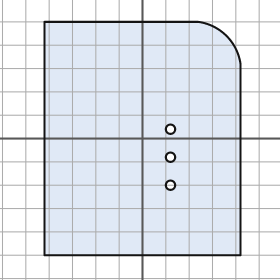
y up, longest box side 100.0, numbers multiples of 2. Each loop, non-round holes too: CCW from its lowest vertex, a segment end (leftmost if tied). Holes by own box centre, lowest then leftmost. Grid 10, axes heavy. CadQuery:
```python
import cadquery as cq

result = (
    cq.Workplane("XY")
    .moveTo(-42.0, -50.0)
    .lineTo(42.0, -50.0)
    .lineTo(42.0, 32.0)
    .threePointArc((36.0, 44.0), (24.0, 50.0))
    .lineTo(-42.0, 50.0)
    .close()
    .moveTo(12.0, -20.0)
    .circle(2.0)
    .moveTo(12.0, -8.0)
    .circle(2.0)
    .moveTo(12.0, 4.0)
    .circle(2.0)
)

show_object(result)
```